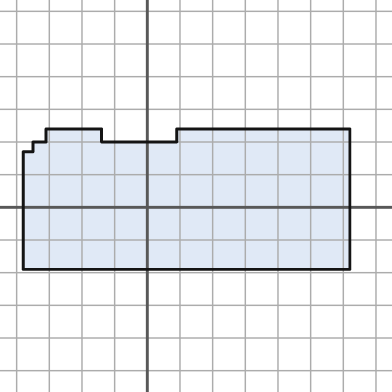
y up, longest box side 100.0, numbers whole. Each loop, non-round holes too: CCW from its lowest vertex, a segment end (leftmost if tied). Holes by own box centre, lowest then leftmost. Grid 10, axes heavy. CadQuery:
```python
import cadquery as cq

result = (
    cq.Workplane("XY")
    .moveTo(-38.0, -19.0)
    .lineTo(62.0, -19.0)
    .lineTo(62.0, 24.0)
    .lineTo(9.0, 24.0)
    .lineTo(9.0, 20.0)
    .lineTo(-14.0, 20.0)
    .lineTo(-14.0, 24.0)
    .lineTo(-31.0, 24.0)
    .lineTo(-31.0, 20.0)
    .lineTo(-35.0, 20.0)
    .lineTo(-35.0, 17.0)
    .lineTo(-38.0, 17.0)
    .close()
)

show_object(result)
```